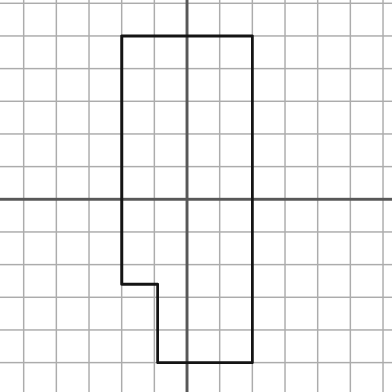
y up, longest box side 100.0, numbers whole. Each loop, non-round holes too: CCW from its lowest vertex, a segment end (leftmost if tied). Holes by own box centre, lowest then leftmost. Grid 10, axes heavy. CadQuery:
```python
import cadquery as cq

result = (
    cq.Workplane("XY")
    .moveTo(-9.0, -50.0)
    .lineTo(20.0, -50.0)
    .lineTo(20.0, 50.0)
    .lineTo(-20.0, 50.0)
    .lineTo(-20.0, -26.0)
    .lineTo(-9.0, -26.0)
    .close()
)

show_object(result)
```